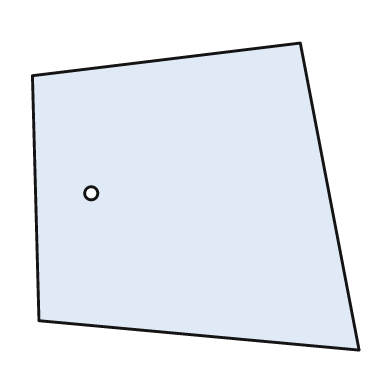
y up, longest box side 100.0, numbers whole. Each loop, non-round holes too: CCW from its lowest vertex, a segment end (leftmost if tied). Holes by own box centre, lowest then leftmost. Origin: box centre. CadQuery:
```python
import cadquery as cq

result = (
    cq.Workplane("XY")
    .moveTo(50.0, -47.0)
    .lineTo(32.0, 47.0)
    .lineTo(-50.0, 37.0)
    .lineTo(-48.0, -38.0)
    .close()
    .moveTo(-32.0, 1.0)
    .circle(2.0)
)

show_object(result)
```